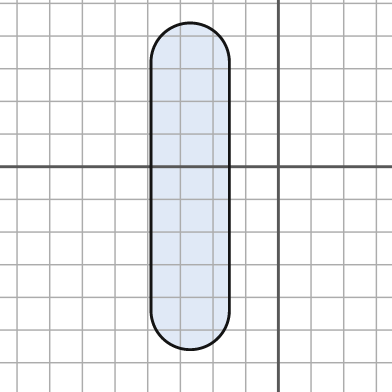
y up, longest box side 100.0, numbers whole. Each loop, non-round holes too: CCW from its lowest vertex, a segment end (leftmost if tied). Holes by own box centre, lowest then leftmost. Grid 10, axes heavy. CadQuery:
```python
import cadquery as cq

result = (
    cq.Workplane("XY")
    .moveTo(-39.0, -44.0)
    .threePointArc((-27.0, -56.0), (-15.0, -44.0))
    .lineTo(-15.0, 32.0)
    .threePointArc((-27.0, 44.0), (-39.0, 32.0))
    .close()
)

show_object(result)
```